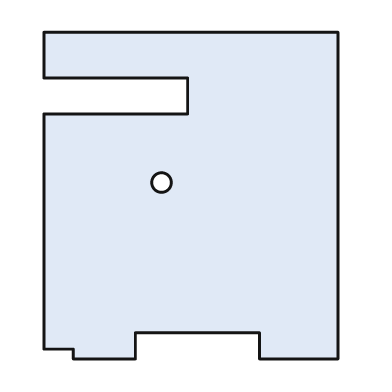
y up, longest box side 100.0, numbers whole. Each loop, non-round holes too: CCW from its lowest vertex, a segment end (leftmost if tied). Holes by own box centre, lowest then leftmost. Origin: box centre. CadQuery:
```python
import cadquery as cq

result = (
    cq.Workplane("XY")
    .moveTo(-36.0, -50.0)
    .lineTo(-17.0, -50.0)
    .lineTo(-17.0, -42.0)
    .lineTo(21.0, -42.0)
    .lineTo(21.0, -50.0)
    .lineTo(45.0, -50.0)
    .lineTo(45.0, 50.0)
    .lineTo(-45.0, 50.0)
    .lineTo(-45.0, 36.0)
    .lineTo(-1.0, 36.0)
    .lineTo(-1.0, 25.0)
    .lineTo(-45.0, 25.0)
    .lineTo(-45.0, -47.0)
    .lineTo(-36.0, -47.0)
    .close()
    .moveTo(-9.0, 4.0)
    .circle(3.0)
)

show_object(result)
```